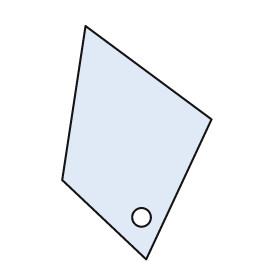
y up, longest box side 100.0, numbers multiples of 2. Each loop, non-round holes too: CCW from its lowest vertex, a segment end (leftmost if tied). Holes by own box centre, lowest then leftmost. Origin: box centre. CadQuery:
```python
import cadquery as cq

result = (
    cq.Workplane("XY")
    .moveTo(4.0, -50.0)
    .lineTo(32.0, 10.0)
    .lineTo(-22.0, 50.0)
    .lineTo(-32.0, -16.0)
    .close()
    .moveTo(2.0, -32.0)
    .circle(4.0)
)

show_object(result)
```